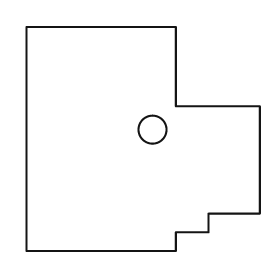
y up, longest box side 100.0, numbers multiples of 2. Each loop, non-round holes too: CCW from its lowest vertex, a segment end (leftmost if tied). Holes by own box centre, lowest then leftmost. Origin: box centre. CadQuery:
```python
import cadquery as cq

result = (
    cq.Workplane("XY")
    .moveTo(-50.0, -48.0)
    .lineTo(14.0, -48.0)
    .lineTo(14.0, -40.0)
    .lineTo(28.0, -40.0)
    .lineTo(28.0, -32.0)
    .lineTo(50.0, -32.0)
    .lineTo(50.0, 14.0)
    .lineTo(14.0, 14.0)
    .lineTo(14.0, 48.0)
    .lineTo(-50.0, 48.0)
    .close()
    .moveTo(4.0, 4.0)
    .circle(6.0)
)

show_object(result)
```